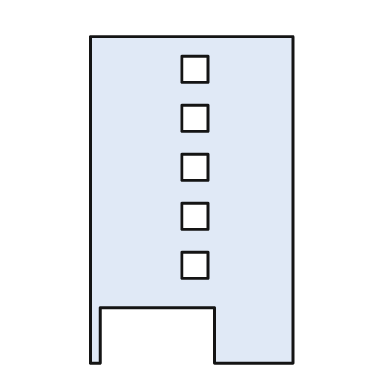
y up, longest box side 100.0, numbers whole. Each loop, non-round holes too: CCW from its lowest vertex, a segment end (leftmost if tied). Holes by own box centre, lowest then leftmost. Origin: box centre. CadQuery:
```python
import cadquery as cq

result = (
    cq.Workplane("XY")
    .moveTo(-31.0, -50.0)
    .lineTo(-28.0, -50.0)
    .lineTo(-28.0, -33.0)
    .lineTo(7.0, -33.0)
    .lineTo(7.0, -50.0)
    .lineTo(31.0, -50.0)
    .lineTo(31.0, 50.0)
    .lineTo(-31.0, 50.0)
    .close()
    .moveTo(-3.0, -24.0)
    .lineTo(5.0, -24.0)
    .lineTo(5.0, -16.0)
    .lineTo(-3.0, -16.0)
    .close()
    .moveTo(-3.0, -9.0)
    .lineTo(5.0, -9.0)
    .lineTo(5.0, -1.0)
    .lineTo(-3.0, -1.0)
    .close()
    .moveTo(-3.0, 6.0)
    .lineTo(5.0, 6.0)
    .lineTo(5.0, 14.0)
    .lineTo(-3.0, 14.0)
    .close()
    .moveTo(-3.0, 21.0)
    .lineTo(5.0, 21.0)
    .lineTo(5.0, 29.0)
    .lineTo(-3.0, 29.0)
    .close()
    .moveTo(-3.0, 36.0)
    .lineTo(5.0, 36.0)
    .lineTo(5.0, 44.0)
    .lineTo(-3.0, 44.0)
    .close()
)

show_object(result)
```